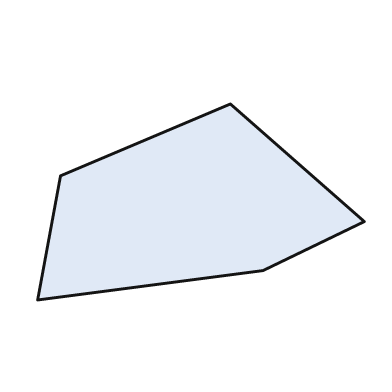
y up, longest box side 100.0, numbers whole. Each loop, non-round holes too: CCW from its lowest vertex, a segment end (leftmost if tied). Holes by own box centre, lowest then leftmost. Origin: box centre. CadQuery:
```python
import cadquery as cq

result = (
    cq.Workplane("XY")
    .moveTo(-50.0, -30.0)
    .lineTo(19.0, -21.0)
    .lineTo(50.0, -6.0)
    .lineTo(9.0, 30.0)
    .lineTo(-43.0, 8.0)
    .close()
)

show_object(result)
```